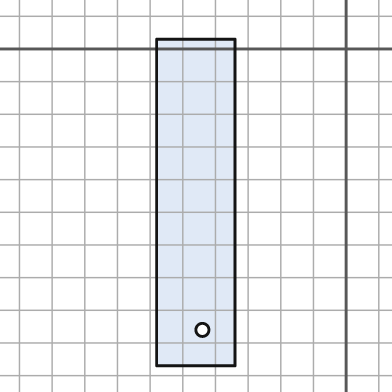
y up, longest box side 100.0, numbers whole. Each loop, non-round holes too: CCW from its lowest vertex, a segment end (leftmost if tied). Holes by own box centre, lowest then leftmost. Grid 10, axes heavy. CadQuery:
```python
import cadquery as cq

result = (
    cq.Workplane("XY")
    .moveTo(-58.0, -97.0)
    .lineTo(-34.0, -97.0)
    .lineTo(-34.0, 3.0)
    .lineTo(-58.0, 3.0)
    .close()
    .moveTo(-44.0, -86.0)
    .circle(2.0)
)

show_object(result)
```